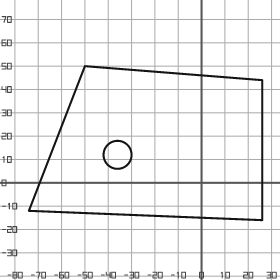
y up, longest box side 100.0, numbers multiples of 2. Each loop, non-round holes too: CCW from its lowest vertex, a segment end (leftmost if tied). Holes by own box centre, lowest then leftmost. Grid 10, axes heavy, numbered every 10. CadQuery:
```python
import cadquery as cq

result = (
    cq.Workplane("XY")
    .moveTo(26.0, -16.0)
    .lineTo(26.0, 44.0)
    .lineTo(-50.0, 50.0)
    .lineTo(-74.0, -12.0)
    .close()
    .moveTo(-36.0, 12.0)
    .circle(6.0)
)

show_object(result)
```